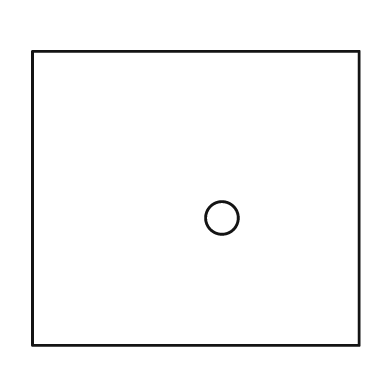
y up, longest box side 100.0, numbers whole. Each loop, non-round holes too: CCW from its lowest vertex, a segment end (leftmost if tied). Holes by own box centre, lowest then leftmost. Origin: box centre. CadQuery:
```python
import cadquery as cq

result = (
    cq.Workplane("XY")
    .moveTo(-50.0, -45.0)
    .lineTo(50.0, -45.0)
    .lineTo(50.0, 45.0)
    .lineTo(-50.0, 45.0)
    .close()
    .moveTo(8.0, -6.0)
    .circle(5.0)
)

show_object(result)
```